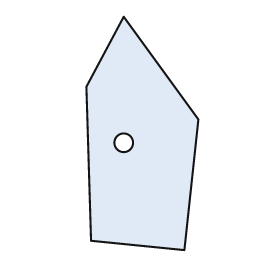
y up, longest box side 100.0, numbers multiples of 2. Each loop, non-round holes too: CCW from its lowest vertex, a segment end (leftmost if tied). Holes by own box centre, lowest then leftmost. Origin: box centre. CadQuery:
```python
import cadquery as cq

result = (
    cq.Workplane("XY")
    .moveTo(18.0, -50.0)
    .lineTo(24.0, 6.0)
    .lineTo(-8.0, 50.0)
    .lineTo(-24.0, 20.0)
    .lineTo(-22.0, -46.0)
    .close()
    .moveTo(-8.0, -4.0)
    .circle(4.0)
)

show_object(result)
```